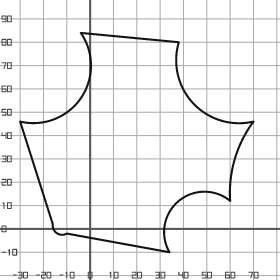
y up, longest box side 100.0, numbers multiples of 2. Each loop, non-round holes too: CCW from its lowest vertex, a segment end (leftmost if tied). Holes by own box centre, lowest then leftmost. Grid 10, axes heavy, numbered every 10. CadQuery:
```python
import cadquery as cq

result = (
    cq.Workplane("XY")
    .moveTo(34.0, -10.0)
    .threePointArc((38.0, 12.0), (60.0, 12.0))
    .threePointArc((62.0, 30.0), (70.0, 46.0))
    .threePointArc((44.0, 54.0), (38.0, 80.0))
    .lineTo(-4.0, 84.0)
    .threePointArc((-4.0, 56.0), (-30.0, 46.0))
    .lineTo(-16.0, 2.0)
    .threePointArc((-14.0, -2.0), (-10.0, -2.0))
    .close()
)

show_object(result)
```